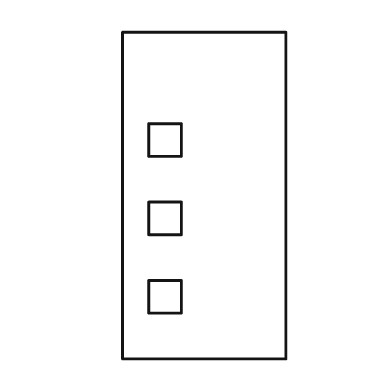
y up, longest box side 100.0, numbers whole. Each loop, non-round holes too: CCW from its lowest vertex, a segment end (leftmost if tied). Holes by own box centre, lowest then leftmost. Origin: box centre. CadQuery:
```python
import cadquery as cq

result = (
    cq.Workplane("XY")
    .moveTo(-25.0, -50.0)
    .lineTo(25.0, -50.0)
    .lineTo(25.0, 50.0)
    .lineTo(-25.0, 50.0)
    .close()
    .moveTo(-17.0, -36.0)
    .lineTo(-7.0, -36.0)
    .lineTo(-7.0, -26.0)
    .lineTo(-17.0, -26.0)
    .close()
    .moveTo(-17.0, -12.0)
    .lineTo(-7.0, -12.0)
    .lineTo(-7.0, -2.0)
    .lineTo(-17.0, -2.0)
    .close()
    .moveTo(-17.0, 12.0)
    .lineTo(-7.0, 12.0)
    .lineTo(-7.0, 22.0)
    .lineTo(-17.0, 22.0)
    .close()
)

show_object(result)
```